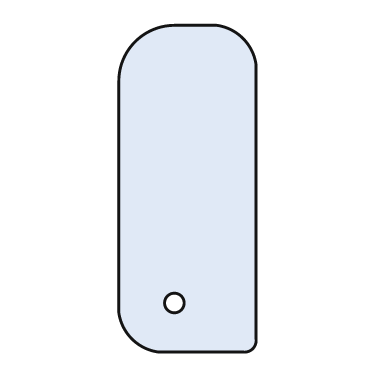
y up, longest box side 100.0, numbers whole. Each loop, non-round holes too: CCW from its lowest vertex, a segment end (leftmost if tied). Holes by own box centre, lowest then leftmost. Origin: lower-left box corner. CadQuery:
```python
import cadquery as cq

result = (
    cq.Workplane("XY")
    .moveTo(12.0, 0.0)
    .lineTo(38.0, 0.0)
    .threePointArc((41.0, 1.0), (42.0, 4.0))
    .lineTo(42.0, 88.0)
    .threePointArc((38.0, 96.0), (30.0, 100.0))
    .lineTo(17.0, 100.0)
    .threePointArc((5.0, 95.0), (0.0, 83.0))
    .lineTo(0.0, 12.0)
    .threePointArc((4.0, 4.0), (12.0, 0.0))
    .close()
    .moveTo(17.0, 15.0)
    .circle(3.0)
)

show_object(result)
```